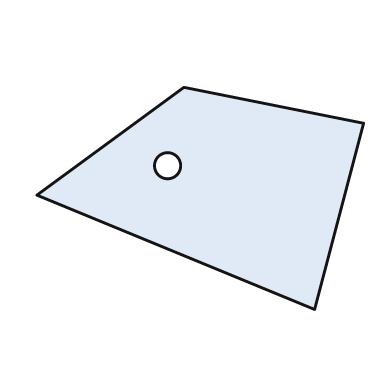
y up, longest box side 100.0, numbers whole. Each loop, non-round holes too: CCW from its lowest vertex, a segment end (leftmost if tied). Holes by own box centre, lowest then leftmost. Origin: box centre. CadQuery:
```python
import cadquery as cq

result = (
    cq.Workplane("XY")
    .moveTo(35.0, -34.0)
    .lineTo(50.0, 23.0)
    .lineTo(-5.0, 34.0)
    .lineTo(-50.0, 1.0)
    .close()
    .moveTo(-10.0, 10.0)
    .circle(4.0)
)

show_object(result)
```